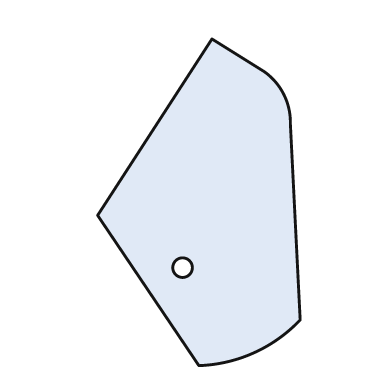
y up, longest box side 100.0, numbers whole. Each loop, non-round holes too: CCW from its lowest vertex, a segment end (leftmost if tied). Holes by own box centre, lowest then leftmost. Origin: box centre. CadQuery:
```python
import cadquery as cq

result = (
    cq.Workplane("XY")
    .moveTo(0.0, -50.0)
    .threePointArc((17.0, -46.0), (31.0, -36.0))
    .lineTo(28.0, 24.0)
    .threePointArc((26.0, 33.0), (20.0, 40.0))
    .lineTo(4.0, 50.0)
    .lineTo(-31.0, -4.0)
    .close()
    .moveTo(-5.0, -20.0)
    .circle(3.0)
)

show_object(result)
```